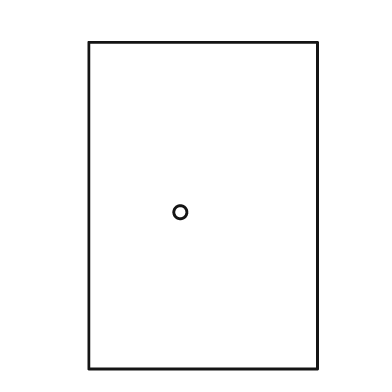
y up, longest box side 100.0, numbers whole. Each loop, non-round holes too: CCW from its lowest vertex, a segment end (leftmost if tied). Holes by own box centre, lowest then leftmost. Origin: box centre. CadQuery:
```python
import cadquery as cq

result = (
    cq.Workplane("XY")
    .moveTo(-35.0, -50.0)
    .lineTo(35.0, -50.0)
    .lineTo(35.0, 50.0)
    .lineTo(-35.0, 50.0)
    .close()
    .moveTo(-7.0, -2.0)
    .circle(2.0)
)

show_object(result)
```